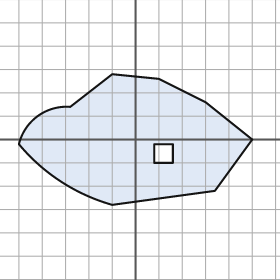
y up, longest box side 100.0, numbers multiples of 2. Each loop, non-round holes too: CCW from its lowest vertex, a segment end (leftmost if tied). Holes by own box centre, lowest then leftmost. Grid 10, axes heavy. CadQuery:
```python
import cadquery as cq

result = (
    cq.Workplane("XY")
    .moveTo(-10.0, -28.0)
    .lineTo(34.0, -22.0)
    .lineTo(50.0, 0.0)
    .lineTo(30.0, 16.0)
    .lineTo(10.0, 26.0)
    .lineTo(-10.0, 28.0)
    .lineTo(-28.0, 14.0)
    .threePointArc((-42.0, 10.0), (-50.0, -2.0))
    .threePointArc((-32.0, -18.0), (-10.0, -28.0))
    .close()
    .moveTo(8.0, -10.0)
    .lineTo(16.0, -10.0)
    .lineTo(16.0, -2.0)
    .lineTo(8.0, -2.0)
    .close()
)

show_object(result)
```